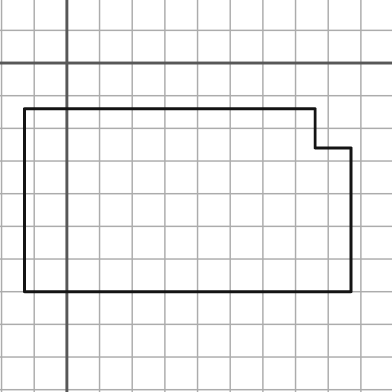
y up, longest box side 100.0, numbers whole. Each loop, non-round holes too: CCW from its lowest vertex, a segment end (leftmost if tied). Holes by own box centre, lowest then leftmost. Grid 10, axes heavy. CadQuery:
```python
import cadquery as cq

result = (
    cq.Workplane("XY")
    .moveTo(-13.0, -70.0)
    .lineTo(87.0, -70.0)
    .lineTo(87.0, -26.0)
    .lineTo(76.0, -26.0)
    .lineTo(76.0, -14.0)
    .lineTo(-13.0, -14.0)
    .close()
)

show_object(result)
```